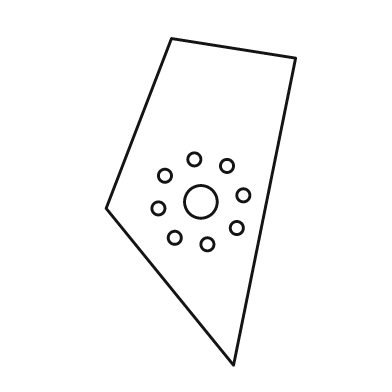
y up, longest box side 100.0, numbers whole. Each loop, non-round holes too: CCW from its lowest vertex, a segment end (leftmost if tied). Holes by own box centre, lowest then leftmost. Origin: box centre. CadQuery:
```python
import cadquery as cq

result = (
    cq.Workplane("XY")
    .moveTo(10.0, -50.0)
    .lineTo(29.0, 44.0)
    .lineTo(-9.0, 50.0)
    .lineTo(-29.0, -2.0)
    .close()
    .moveTo(2.0, -13.0)
    .circle(2.0)
    .moveTo(-8.0, -11.0)
    .circle(2.0)
    .moveTo(11.0, -8.0)
    .circle(2.0)
    .moveTo(-13.0, -2.0)
    .circle(2.0)
    .moveTo(0.0, 0.0)
    .circle(5.0)
    .moveTo(13.0, 2.0)
    .circle(2.0)
    .moveTo(-11.0, 8.0)
    .circle(2.0)
    .moveTo(8.0, 11.0)
    .circle(2.0)
    .moveTo(-2.0, 13.0)
    .circle(2.0)
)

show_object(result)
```